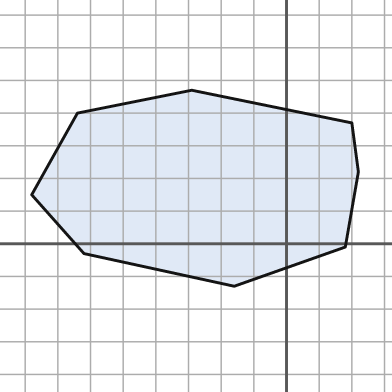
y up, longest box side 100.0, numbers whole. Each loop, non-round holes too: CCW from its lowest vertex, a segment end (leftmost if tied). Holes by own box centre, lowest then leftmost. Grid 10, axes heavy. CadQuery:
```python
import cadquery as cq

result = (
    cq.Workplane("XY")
    .moveTo(-16.0, -13.0)
    .lineTo(18.0, -1.0)
    .lineTo(22.0, 22.0)
    .lineTo(20.0, 37.0)
    .lineTo(-29.0, 47.0)
    .lineTo(-64.0, 40.0)
    .lineTo(-78.0, 15.0)
    .lineTo(-62.0, -3.0)
    .close()
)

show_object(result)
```